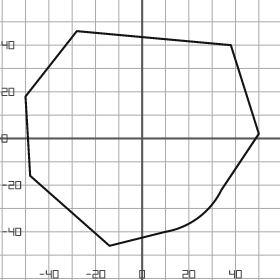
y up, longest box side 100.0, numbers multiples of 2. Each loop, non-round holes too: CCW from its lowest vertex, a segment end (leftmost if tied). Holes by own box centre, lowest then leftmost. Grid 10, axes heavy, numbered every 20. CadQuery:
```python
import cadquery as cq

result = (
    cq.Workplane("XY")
    .moveTo(-14.0, -46.0)
    .lineTo(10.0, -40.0)
    .threePointArc((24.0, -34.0), (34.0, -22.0))
    .lineTo(50.0, 2.0)
    .lineTo(38.0, 40.0)
    .lineTo(-28.0, 46.0)
    .lineTo(-50.0, 18.0)
    .lineTo(-48.0, -16.0)
    .close()
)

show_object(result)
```